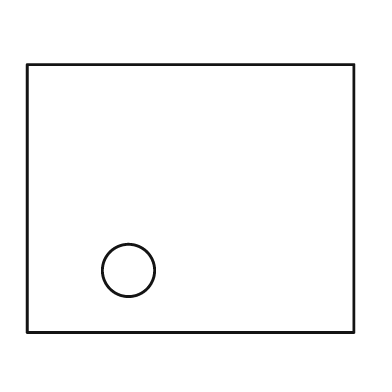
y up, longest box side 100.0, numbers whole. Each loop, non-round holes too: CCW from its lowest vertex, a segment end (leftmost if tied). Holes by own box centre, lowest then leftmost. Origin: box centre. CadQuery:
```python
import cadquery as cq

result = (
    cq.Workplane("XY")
    .moveTo(-50.0, -41.0)
    .lineTo(50.0, -41.0)
    .lineTo(50.0, 41.0)
    .lineTo(-50.0, 41.0)
    .close()
    .moveTo(-19.0, -22.0)
    .circle(8.0)
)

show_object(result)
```